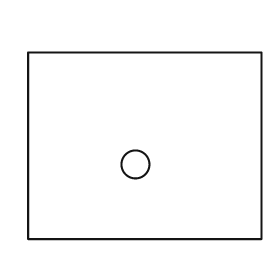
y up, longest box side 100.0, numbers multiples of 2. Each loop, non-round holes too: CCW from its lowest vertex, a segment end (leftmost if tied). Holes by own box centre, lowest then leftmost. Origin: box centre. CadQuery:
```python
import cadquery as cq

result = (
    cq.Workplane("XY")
    .moveTo(-50.0, -40.0)
    .lineTo(50.0, -40.0)
    .lineTo(50.0, 40.0)
    .lineTo(-50.0, 40.0)
    .close()
    .moveTo(-4.0, -8.0)
    .circle(6.0)
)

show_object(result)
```